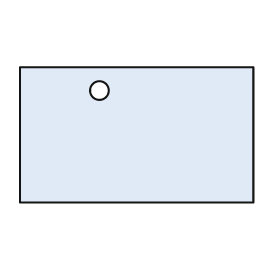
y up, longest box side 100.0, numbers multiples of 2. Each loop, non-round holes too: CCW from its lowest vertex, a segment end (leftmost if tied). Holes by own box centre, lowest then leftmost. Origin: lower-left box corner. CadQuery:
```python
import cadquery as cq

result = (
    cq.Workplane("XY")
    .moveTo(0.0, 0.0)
    .lineTo(100.0, 0.0)
    .lineTo(100.0, 58.0)
    .lineTo(0.0, 58.0)
    .close()
    .moveTo(34.0, 48.0)
    .circle(4.0)
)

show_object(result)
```